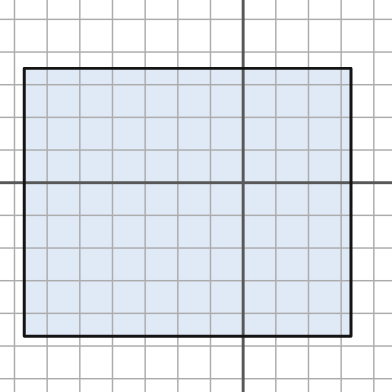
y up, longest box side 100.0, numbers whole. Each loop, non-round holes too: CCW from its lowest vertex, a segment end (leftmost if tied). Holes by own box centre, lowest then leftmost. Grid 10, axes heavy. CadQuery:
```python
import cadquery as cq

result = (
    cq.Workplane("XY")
    .moveTo(-67.0, -47.0)
    .lineTo(33.0, -47.0)
    .lineTo(33.0, 35.0)
    .lineTo(-67.0, 35.0)
    .close()
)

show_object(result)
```